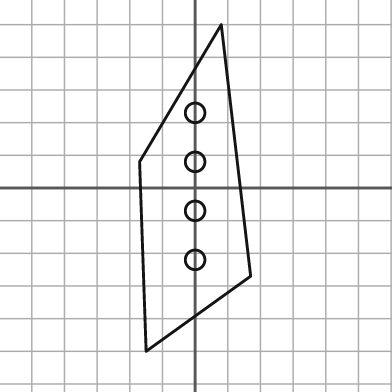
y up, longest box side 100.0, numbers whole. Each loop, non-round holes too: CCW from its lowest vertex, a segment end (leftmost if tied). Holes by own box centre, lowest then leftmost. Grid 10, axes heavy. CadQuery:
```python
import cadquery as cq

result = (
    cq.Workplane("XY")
    .moveTo(-15.0, -50.0)
    .lineTo(17.0, -27.0)
    .lineTo(8.0, 50.0)
    .lineTo(-17.0, 8.0)
    .close()
    .moveTo(0.0, -22.0)
    .circle(3.0)
    .moveTo(0.0, -7.0)
    .circle(3.0)
    .moveTo(0.0, 8.0)
    .circle(3.0)
    .moveTo(0.0, 23.0)
    .circle(3.0)
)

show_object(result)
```